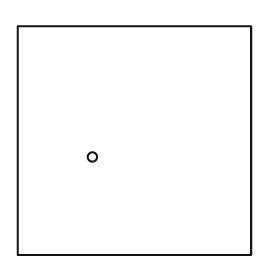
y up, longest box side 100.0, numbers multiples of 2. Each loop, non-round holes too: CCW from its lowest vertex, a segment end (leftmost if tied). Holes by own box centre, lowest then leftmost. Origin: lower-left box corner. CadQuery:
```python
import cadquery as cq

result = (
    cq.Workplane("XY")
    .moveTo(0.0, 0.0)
    .lineTo(100.0, 0.0)
    .lineTo(100.0, 98.0)
    .lineTo(0.0, 98.0)
    .close()
    .moveTo(32.0, 42.0)
    .circle(2.0)
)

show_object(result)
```